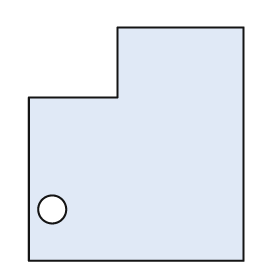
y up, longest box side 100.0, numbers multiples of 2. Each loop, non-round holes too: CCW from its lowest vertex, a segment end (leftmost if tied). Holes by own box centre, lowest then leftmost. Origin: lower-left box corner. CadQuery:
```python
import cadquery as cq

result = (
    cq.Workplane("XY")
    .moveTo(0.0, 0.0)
    .lineTo(92.0, 0.0)
    .lineTo(92.0, 100.0)
    .lineTo(38.0, 100.0)
    .lineTo(38.0, 70.0)
    .lineTo(0.0, 70.0)
    .close()
    .moveTo(10.0, 22.0)
    .circle(6.0)
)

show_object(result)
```